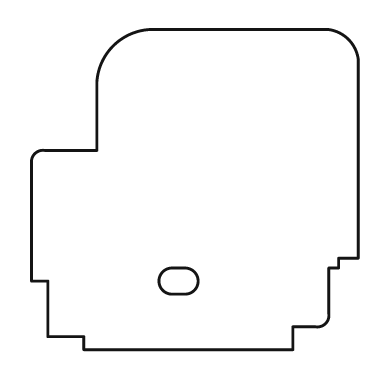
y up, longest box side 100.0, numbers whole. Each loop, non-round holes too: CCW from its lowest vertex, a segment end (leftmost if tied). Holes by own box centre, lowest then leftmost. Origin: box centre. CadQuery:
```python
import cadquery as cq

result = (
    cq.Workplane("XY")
    .moveTo(-34.0, -49.0)
    .lineTo(30.0, -49.0)
    .lineTo(30.0, -42.0)
    .lineTo(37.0, -42.0)
    .threePointArc((40.0, -41.0), (41.0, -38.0))
    .lineTo(41.0, -24.0)
    .lineTo(44.0, -24.0)
    .lineTo(44.0, -21.0)
    .lineTo(50.0, -21.0)
    .lineTo(50.0, 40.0)
    .threePointArc((47.0, 46.0), (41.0, 49.0))
    .lineTo(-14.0, 49.0)
    .threePointArc((-25.0, 44.0), (-30.0, 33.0))
    .lineTo(-30.0, 12.0)
    .lineTo(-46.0, 12.0)
    .threePointArc((-49.0, 11.0), (-50.0, 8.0))
    .lineTo(-50.0, -28.0)
    .lineTo(-45.0, -28.0)
    .lineTo(-45.0, -45.0)
    .lineTo(-34.0, -45.0)
    .close()
    .moveTo(-7.0, -32.0)
    .lineTo(-3.0, -32.0)
    .threePointArc((1.0, -28.0), (-3.0, -24.0))
    .lineTo(-7.0, -24.0)
    .threePointArc((-11.0, -28.0), (-7.0, -32.0))
    .close()
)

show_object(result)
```